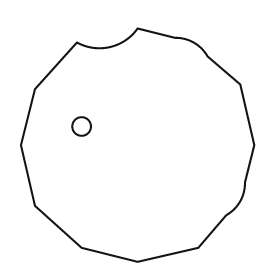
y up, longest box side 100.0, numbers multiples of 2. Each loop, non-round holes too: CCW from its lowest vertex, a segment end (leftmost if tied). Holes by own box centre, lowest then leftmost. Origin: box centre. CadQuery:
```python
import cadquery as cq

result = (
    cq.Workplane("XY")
    .moveTo(0.0, -50.0)
    .lineTo(26.0, -44.0)
    .lineTo(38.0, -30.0)
    .threePointArc((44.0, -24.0), (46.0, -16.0))
    .lineTo(50.0, 0.0)
    .lineTo(44.0, 26.0)
    .lineTo(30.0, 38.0)
    .threePointArc((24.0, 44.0), (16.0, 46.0))
    .lineTo(0.0, 50.0)
    .threePointArc((-12.0, 42.0), (-26.0, 44.0))
    .lineTo(-44.0, 24.0)
    .lineTo(-50.0, 0.0)
    .lineTo(-44.0, -26.0)
    .lineTo(-24.0, -44.0)
    .close()
    .moveTo(-24.0, 8.0)
    .circle(4.0)
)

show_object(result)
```